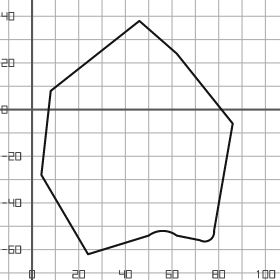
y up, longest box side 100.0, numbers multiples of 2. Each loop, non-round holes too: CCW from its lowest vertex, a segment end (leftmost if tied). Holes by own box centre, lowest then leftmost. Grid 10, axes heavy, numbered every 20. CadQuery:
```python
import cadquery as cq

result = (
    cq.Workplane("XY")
    .moveTo(24.0, -62.0)
    .lineTo(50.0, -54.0)
    .threePointArc((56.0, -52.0), (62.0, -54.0))
    .lineTo(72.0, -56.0)
    .threePointArc((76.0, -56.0), (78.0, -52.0))
    .lineTo(86.0, -6.0)
    .lineTo(62.0, 24.0)
    .lineTo(46.0, 38.0)
    .lineTo(8.0, 8.0)
    .lineTo(4.0, -28.0)
    .close()
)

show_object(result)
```